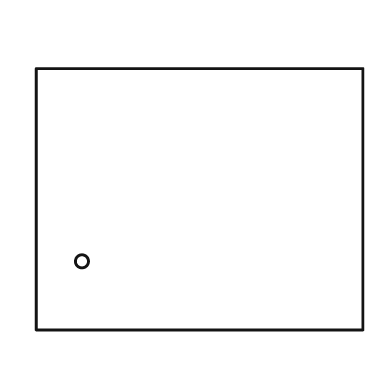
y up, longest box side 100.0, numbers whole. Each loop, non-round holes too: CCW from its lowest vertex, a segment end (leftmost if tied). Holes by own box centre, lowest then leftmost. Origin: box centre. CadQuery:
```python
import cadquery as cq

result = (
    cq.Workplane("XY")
    .moveTo(-50.0, -40.0)
    .lineTo(50.0, -40.0)
    .lineTo(50.0, 40.0)
    .lineTo(-50.0, 40.0)
    .close()
    .moveTo(-36.0, -19.0)
    .circle(2.0)
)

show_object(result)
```